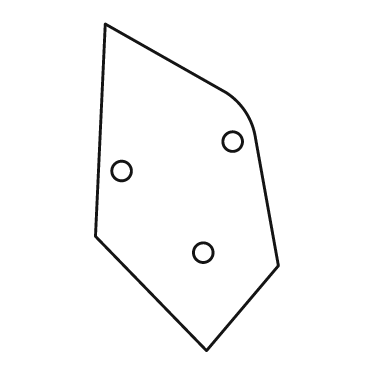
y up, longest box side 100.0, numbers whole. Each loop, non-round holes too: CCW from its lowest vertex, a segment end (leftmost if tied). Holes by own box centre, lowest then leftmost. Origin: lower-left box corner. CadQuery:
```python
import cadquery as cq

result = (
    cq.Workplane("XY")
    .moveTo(34.0, 0.0)
    .lineTo(56.0, 26.0)
    .lineTo(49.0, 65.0)
    .threePointArc((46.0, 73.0), (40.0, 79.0))
    .lineTo(3.0, 100.0)
    .lineTo(0.0, 35.0)
    .close()
    .moveTo(33.0, 30.0)
    .circle(3.0)
    .moveTo(8.0, 55.0)
    .circle(3.0)
    .moveTo(42.0, 64.0)
    .circle(3.0)
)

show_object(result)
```